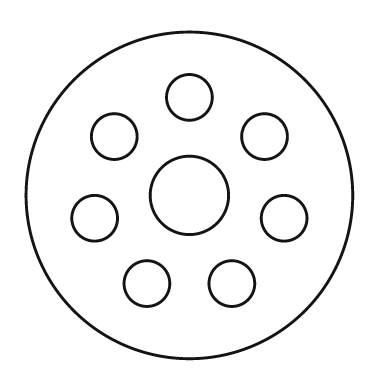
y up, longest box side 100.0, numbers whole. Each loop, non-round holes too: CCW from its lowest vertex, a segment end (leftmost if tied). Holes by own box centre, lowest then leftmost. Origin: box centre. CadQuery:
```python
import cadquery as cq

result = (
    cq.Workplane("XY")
    .moveTo(0.0, 0.0)
    .circle(50.0)
    .moveTo(-13.0, -27.0)
    .circle(7.0)
    .moveTo(13.0, -27.0)
    .circle(7.0)
    .moveTo(-29.0, -7.0)
    .circle(7.0)
    .moveTo(29.0, -7.0)
    .circle(7.0)
    .moveTo(0.0, 0.0)
    .circle(12.0)
    .moveTo(-23.0, 18.0)
    .circle(7.0)
    .moveTo(23.0, 18.0)
    .circle(7.0)
    .moveTo(0.0, 30.0)
    .circle(7.0)
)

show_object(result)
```